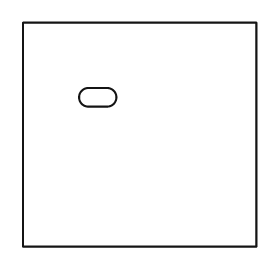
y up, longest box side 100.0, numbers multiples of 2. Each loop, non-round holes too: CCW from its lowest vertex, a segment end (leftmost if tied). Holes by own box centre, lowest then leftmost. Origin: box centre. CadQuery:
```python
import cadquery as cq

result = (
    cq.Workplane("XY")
    .moveTo(-50.0, -48.0)
    .lineTo(50.0, -48.0)
    .lineTo(50.0, 48.0)
    .lineTo(-50.0, 48.0)
    .close()
    .moveTo(-22.0, 12.0)
    .lineTo(-14.0, 12.0)
    .threePointArc((-10.0, 16.0), (-14.0, 20.0))
    .lineTo(-22.0, 20.0)
    .threePointArc((-26.0, 16.0), (-22.0, 12.0))
    .close()
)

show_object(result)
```